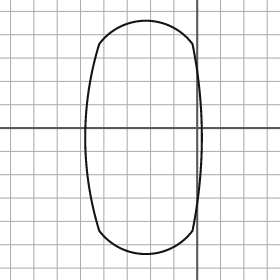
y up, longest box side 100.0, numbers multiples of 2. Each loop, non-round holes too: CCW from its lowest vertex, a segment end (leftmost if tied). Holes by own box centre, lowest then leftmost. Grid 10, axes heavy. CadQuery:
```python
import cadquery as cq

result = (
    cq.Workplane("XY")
    .moveTo(-42.0, -44.0)
    .threePointArc((-22.0, -54.0), (-2.0, -44.0))
    .threePointArc((2.0, -4.0), (-2.0, 36.0))
    .threePointArc((-22.0, 46.0), (-42.0, 36.0))
    .threePointArc((-48.0, -4.0), (-42.0, -44.0))
    .close()
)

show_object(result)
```